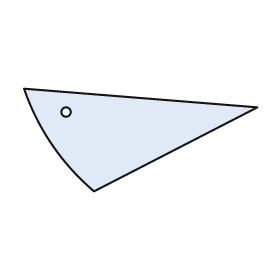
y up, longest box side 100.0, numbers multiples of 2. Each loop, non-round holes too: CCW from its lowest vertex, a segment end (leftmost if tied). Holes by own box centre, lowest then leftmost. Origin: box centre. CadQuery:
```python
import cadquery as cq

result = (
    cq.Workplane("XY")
    .moveTo(-20.0, -22.0)
    .lineTo(50.0, 14.0)
    .lineTo(-50.0, 22.0)
    .threePointArc((-38.0, -2.0), (-20.0, -22.0))
    .close()
    .moveTo(-32.0, 12.0)
    .circle(2.0)
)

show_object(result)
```